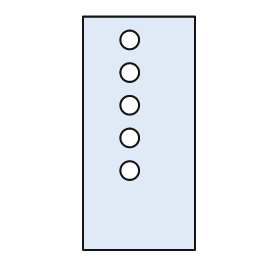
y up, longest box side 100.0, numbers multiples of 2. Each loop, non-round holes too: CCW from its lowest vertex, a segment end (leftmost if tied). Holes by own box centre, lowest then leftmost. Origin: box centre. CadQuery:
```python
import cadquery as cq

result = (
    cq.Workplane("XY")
    .moveTo(-24.0, -50.0)
    .lineTo(24.0, -50.0)
    .lineTo(24.0, 50.0)
    .lineTo(-24.0, 50.0)
    .close()
    .moveTo(-4.0, -16.0)
    .circle(4.0)
    .moveTo(-4.0, -2.0)
    .circle(4.0)
    .moveTo(-4.0, 12.0)
    .circle(4.0)
    .moveTo(-4.0, 26.0)
    .circle(4.0)
    .moveTo(-4.0, 40.0)
    .circle(4.0)
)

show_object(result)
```